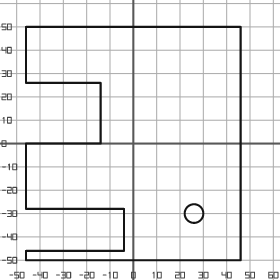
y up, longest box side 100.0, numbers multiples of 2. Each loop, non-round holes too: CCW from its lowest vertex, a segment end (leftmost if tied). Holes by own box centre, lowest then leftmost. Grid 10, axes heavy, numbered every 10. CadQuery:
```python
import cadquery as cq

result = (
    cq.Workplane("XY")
    .moveTo(-46.0, -50.0)
    .lineTo(46.0, -50.0)
    .lineTo(46.0, 50.0)
    .lineTo(-46.0, 50.0)
    .lineTo(-46.0, 26.0)
    .lineTo(-14.0, 26.0)
    .lineTo(-14.0, 0.0)
    .lineTo(-46.0, 0.0)
    .lineTo(-46.0, -28.0)
    .lineTo(-4.0, -28.0)
    .lineTo(-4.0, -46.0)
    .lineTo(-46.0, -46.0)
    .close()
    .moveTo(26.0, -30.0)
    .circle(4.0)
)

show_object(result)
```